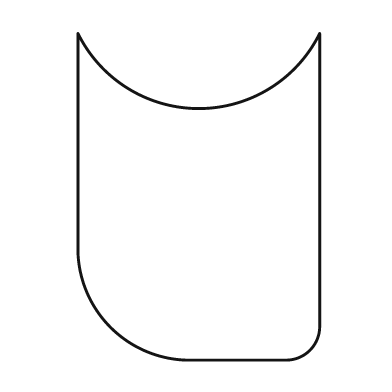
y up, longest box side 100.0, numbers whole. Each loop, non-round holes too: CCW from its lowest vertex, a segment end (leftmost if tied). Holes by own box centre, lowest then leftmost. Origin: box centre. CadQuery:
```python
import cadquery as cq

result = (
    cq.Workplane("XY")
    .moveTo(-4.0, -50.0)
    .lineTo(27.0, -50.0)
    .threePointArc((34.0, -47.0), (37.0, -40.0))
    .lineTo(37.0, 50.0)
    .threePointArc((0.0, 27.0), (-37.0, 50.0))
    .lineTo(-37.0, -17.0)
    .threePointArc((-27.0, -40.0), (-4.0, -50.0))
    .close()
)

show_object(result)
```